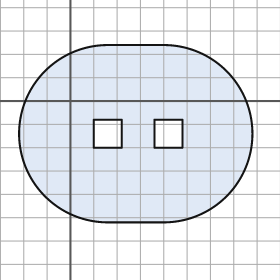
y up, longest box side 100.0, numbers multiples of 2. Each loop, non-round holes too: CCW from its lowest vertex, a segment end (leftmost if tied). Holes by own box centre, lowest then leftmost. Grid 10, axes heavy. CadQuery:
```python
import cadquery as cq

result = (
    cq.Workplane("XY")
    .moveTo(16.0, -52.0)
    .lineTo(40.0, -52.0)
    .threePointArc((78.0, -14.0), (40.0, 24.0))
    .lineTo(16.0, 24.0)
    .threePointArc((-22.0, -14.0), (16.0, -52.0))
    .close()
    .moveTo(10.0, -20.0)
    .lineTo(22.0, -20.0)
    .lineTo(22.0, -8.0)
    .lineTo(10.0, -8.0)
    .close()
    .moveTo(36.0, -20.0)
    .lineTo(48.0, -20.0)
    .lineTo(48.0, -8.0)
    .lineTo(36.0, -8.0)
    .close()
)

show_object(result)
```